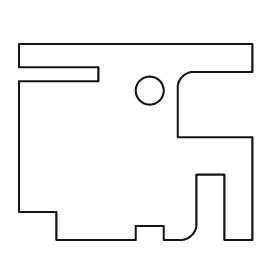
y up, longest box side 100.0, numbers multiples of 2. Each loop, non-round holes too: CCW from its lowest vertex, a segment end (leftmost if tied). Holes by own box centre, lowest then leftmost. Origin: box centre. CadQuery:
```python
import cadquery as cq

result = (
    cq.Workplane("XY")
    .moveTo(-34.0, -42.0)
    .lineTo(0.0, -42.0)
    .lineTo(0.0, -36.0)
    .lineTo(12.0, -36.0)
    .lineTo(12.0, -42.0)
    .lineTo(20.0, -42.0)
    .threePointArc((24.0, -40.0), (26.0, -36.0))
    .lineTo(26.0, -14.0)
    .lineTo(38.0, -14.0)
    .lineTo(38.0, -42.0)
    .lineTo(50.0, -42.0)
    .lineTo(50.0, 2.0)
    .lineTo(18.0, 2.0)
    .lineTo(18.0, 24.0)
    .threePointArc((20.0, 28.0), (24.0, 30.0))
    .lineTo(50.0, 30.0)
    .lineTo(50.0, 42.0)
    .lineTo(-50.0, 42.0)
    .lineTo(-50.0, 32.0)
    .lineTo(-16.0, 32.0)
    .lineTo(-16.0, 26.0)
    .lineTo(-50.0, 26.0)
    .lineTo(-50.0, -30.0)
    .lineTo(-34.0, -30.0)
    .close()
    .moveTo(6.0, 22.0)
    .circle(6.0)
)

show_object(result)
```